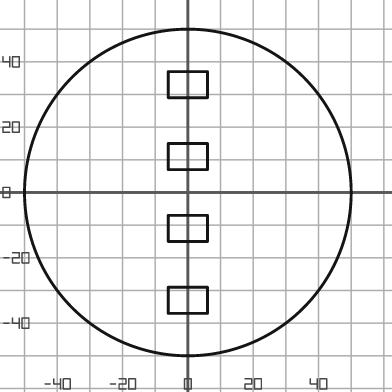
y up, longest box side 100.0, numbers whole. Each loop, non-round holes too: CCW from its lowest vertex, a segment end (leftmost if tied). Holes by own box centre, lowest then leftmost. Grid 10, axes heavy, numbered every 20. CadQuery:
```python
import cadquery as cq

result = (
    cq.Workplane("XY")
    .moveTo(0.0, 0.0)
    .circle(50.0)
    .moveTo(-6.0, -37.0)
    .lineTo(6.0, -37.0)
    .lineTo(6.0, -29.0)
    .lineTo(-6.0, -29.0)
    .close()
    .moveTo(-6.0, -15.0)
    .lineTo(6.0, -15.0)
    .lineTo(6.0, -7.0)
    .lineTo(-6.0, -7.0)
    .close()
    .moveTo(-6.0, 7.0)
    .lineTo(6.0, 7.0)
    .lineTo(6.0, 15.0)
    .lineTo(-6.0, 15.0)
    .close()
    .moveTo(-6.0, 29.0)
    .lineTo(6.0, 29.0)
    .lineTo(6.0, 37.0)
    .lineTo(-6.0, 37.0)
    .close()
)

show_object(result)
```